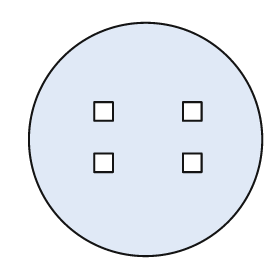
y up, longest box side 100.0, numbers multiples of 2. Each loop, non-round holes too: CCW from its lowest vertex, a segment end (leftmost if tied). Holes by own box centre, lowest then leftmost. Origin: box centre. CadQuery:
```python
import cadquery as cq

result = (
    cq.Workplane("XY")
    .moveTo(0.0, 0.0)
    .circle(50.0)
    .moveTo(-22.0, -14.0)
    .lineTo(-14.0, -14.0)
    .lineTo(-14.0, -6.0)
    .lineTo(-22.0, -6.0)
    .close()
    .moveTo(16.0, -14.0)
    .lineTo(24.0, -14.0)
    .lineTo(24.0, -6.0)
    .lineTo(16.0, -6.0)
    .close()
    .moveTo(-22.0, 8.0)
    .lineTo(-14.0, 8.0)
    .lineTo(-14.0, 16.0)
    .lineTo(-22.0, 16.0)
    .close()
    .moveTo(16.0, 8.0)
    .lineTo(24.0, 8.0)
    .lineTo(24.0, 16.0)
    .lineTo(16.0, 16.0)
    .close()
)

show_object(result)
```